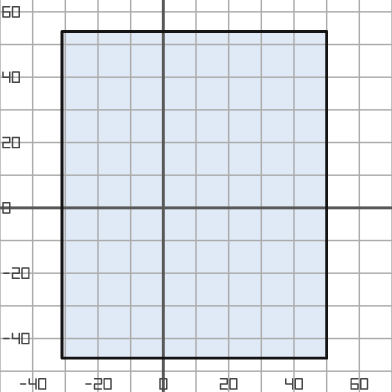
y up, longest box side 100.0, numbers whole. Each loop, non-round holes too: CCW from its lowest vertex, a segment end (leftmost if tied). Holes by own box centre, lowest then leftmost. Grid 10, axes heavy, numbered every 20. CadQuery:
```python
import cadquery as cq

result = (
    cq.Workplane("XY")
    .moveTo(-31.0, -46.0)
    .lineTo(50.0, -46.0)
    .lineTo(50.0, 54.0)
    .lineTo(-31.0, 54.0)
    .close()
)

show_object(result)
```